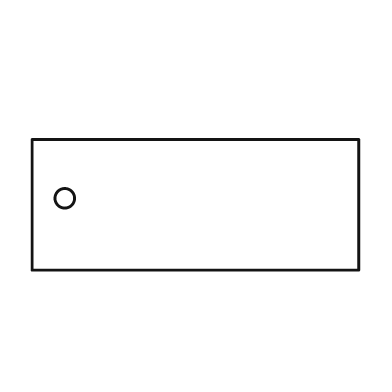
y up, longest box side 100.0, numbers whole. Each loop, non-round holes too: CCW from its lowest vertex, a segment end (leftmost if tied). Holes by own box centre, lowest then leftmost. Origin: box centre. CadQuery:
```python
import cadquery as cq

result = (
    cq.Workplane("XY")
    .moveTo(-50.0, -20.0)
    .lineTo(50.0, -20.0)
    .lineTo(50.0, 20.0)
    .lineTo(-50.0, 20.0)
    .close()
    .moveTo(-40.0, 2.0)
    .circle(3.0)
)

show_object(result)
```